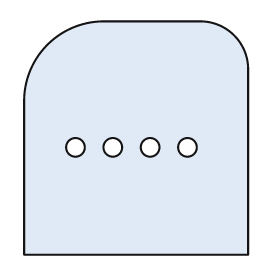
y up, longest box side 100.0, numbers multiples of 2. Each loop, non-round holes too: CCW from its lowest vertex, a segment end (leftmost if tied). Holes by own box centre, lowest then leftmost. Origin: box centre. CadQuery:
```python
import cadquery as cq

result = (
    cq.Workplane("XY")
    .moveTo(-48.0, -50.0)
    .lineTo(48.0, -50.0)
    .lineTo(48.0, 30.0)
    .threePointArc((42.0, 44.0), (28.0, 50.0))
    .lineTo(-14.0, 50.0)
    .threePointArc((-38.0, 40.0), (-48.0, 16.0))
    .close()
    .moveTo(-26.0, -4.0)
    .circle(4.0)
    .moveTo(-10.0, -4.0)
    .circle(4.0)
    .moveTo(6.0, -4.0)
    .circle(4.0)
    .moveTo(22.0, -4.0)
    .circle(4.0)
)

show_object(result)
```